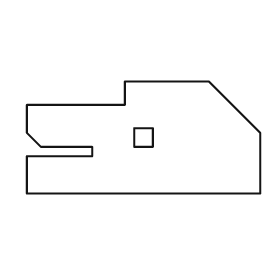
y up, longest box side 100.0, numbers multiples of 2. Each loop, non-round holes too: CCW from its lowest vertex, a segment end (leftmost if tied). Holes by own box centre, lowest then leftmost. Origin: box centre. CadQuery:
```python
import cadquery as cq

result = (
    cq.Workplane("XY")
    .moveTo(-50.0, -24.0)
    .lineTo(50.0, -24.0)
    .lineTo(50.0, 2.0)
    .lineTo(28.0, 24.0)
    .lineTo(-8.0, 24.0)
    .lineTo(-8.0, 14.0)
    .lineTo(-50.0, 14.0)
    .lineTo(-50.0, 2.0)
    .lineTo(-44.0, -4.0)
    .lineTo(-22.0, -4.0)
    .lineTo(-22.0, -8.0)
    .lineTo(-50.0, -8.0)
    .close()
    .moveTo(-4.0, -4.0)
    .lineTo(4.0, -4.0)
    .lineTo(4.0, 4.0)
    .lineTo(-4.0, 4.0)
    .close()
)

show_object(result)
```